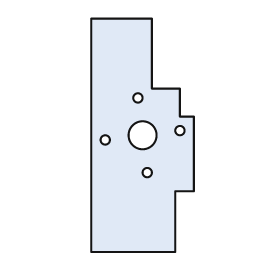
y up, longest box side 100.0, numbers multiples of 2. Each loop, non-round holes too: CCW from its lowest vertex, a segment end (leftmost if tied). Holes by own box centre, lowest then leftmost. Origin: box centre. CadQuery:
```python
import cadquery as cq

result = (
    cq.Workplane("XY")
    .moveTo(-22.0, -50.0)
    .lineTo(14.0, -50.0)
    .lineTo(14.0, -24.0)
    .lineTo(22.0, -24.0)
    .lineTo(22.0, 8.0)
    .lineTo(16.0, 8.0)
    .lineTo(16.0, 20.0)
    .lineTo(4.0, 20.0)
    .lineTo(4.0, 50.0)
    .lineTo(-22.0, 50.0)
    .close()
    .moveTo(2.0, -16.0)
    .circle(2.0)
    .moveTo(-16.0, -2.0)
    .circle(2.0)
    .moveTo(0.0, 0.0)
    .circle(6.0)
    .moveTo(16.0, 2.0)
    .circle(2.0)
    .moveTo(-2.0, 16.0)
    .circle(2.0)
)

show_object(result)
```